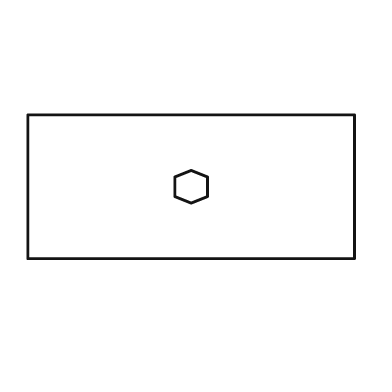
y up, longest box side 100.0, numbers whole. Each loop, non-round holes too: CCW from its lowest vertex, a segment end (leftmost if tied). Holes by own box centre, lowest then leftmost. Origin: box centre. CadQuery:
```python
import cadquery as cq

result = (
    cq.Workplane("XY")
    .moveTo(-50.0, -22.0)
    .lineTo(50.0, -22.0)
    .lineTo(50.0, 22.0)
    .lineTo(-50.0, 22.0)
    .close()
    .moveTo(0.0, -5.0)
    .lineTo(5.0, -3.0)
    .lineTo(5.0, 3.0)
    .lineTo(0.0, 5.0)
    .lineTo(-5.0, 3.0)
    .lineTo(-5.0, -3.0)
    .close()
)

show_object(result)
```